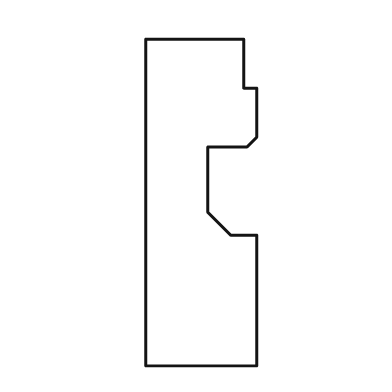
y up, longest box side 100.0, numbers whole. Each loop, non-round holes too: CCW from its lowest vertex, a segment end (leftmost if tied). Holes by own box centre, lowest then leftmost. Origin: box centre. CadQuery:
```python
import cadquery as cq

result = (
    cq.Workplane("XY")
    .moveTo(-17.0, -50.0)
    .lineTo(17.0, -50.0)
    .lineTo(17.0, -10.0)
    .lineTo(9.0, -10.0)
    .lineTo(2.0, -3.0)
    .lineTo(2.0, 17.0)
    .lineTo(14.0, 17.0)
    .lineTo(17.0, 20.0)
    .lineTo(17.0, 35.0)
    .lineTo(13.0, 35.0)
    .lineTo(13.0, 50.0)
    .lineTo(-17.0, 50.0)
    .close()
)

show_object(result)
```